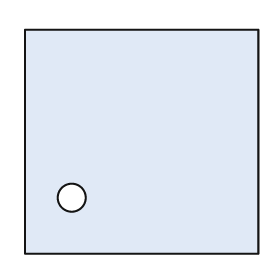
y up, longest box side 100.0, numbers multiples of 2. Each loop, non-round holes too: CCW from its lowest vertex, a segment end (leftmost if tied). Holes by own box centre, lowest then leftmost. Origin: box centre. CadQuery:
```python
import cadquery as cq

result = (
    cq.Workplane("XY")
    .moveTo(-50.0, -48.0)
    .lineTo(50.0, -48.0)
    .lineTo(50.0, 48.0)
    .lineTo(-50.0, 48.0)
    .close()
    .moveTo(-30.0, -24.0)
    .circle(6.0)
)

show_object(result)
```